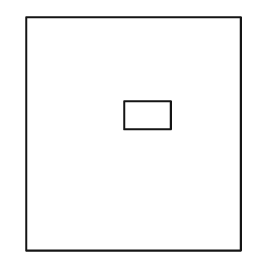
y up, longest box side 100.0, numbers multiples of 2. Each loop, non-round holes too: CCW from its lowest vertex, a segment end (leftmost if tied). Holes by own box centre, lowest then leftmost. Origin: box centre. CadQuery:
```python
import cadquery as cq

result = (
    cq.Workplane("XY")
    .moveTo(-46.0, -50.0)
    .lineTo(46.0, -50.0)
    .lineTo(46.0, 50.0)
    .lineTo(-46.0, 50.0)
    .close()
    .moveTo(-4.0, 2.0)
    .lineTo(16.0, 2.0)
    .lineTo(16.0, 14.0)
    .lineTo(-4.0, 14.0)
    .close()
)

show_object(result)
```